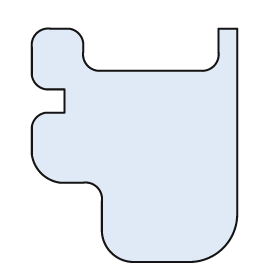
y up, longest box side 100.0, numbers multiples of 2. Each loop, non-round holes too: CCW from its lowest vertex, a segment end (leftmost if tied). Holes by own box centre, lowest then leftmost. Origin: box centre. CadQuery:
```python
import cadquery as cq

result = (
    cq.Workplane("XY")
    .moveTo(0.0, -50.0)
    .lineTo(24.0, -50.0)
    .threePointArc((38.0, -44.0), (44.0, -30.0))
    .lineTo(44.0, 50.0)
    .lineTo(36.0, 50.0)
    .lineTo(36.0, 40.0)
    .threePointArc((34.0, 34.0), (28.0, 32.0))
    .lineTo(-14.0, 32.0)
    .threePointArc((-20.0, 34.0), (-22.0, 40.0))
    .lineTo(-22.0, 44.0)
    .threePointArc((-24.0, 48.0), (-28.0, 50.0))
    .lineTo(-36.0, 50.0)
    .threePointArc((-42.0, 48.0), (-44.0, 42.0))
    .lineTo(-44.0, 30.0)
    .threePointArc((-42.0, 26.0), (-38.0, 24.0))
    .lineTo(-30.0, 24.0)
    .lineTo(-30.0, 14.0)
    .lineTo(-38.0, 14.0)
    .threePointArc((-42.0, 12.0), (-44.0, 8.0))
    .lineTo(-44.0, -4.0)
    .threePointArc((-40.0, -12.0), (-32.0, -16.0))
    .lineTo(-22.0, -16.0)
    .threePointArc((-16.0, -18.0), (-14.0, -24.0))
    .lineTo(-14.0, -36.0)
    .threePointArc((-10.0, -46.0), (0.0, -50.0))
    .close()
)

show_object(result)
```